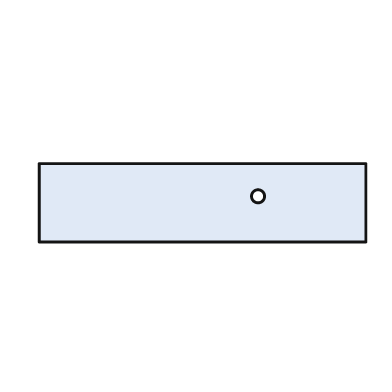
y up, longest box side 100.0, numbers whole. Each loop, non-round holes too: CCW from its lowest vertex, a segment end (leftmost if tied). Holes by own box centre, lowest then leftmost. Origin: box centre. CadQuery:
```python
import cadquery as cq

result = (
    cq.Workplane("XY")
    .moveTo(-50.0, -12.0)
    .lineTo(50.0, -12.0)
    .lineTo(50.0, 12.0)
    .lineTo(-50.0, 12.0)
    .close()
    .moveTo(17.0, 2.0)
    .circle(2.0)
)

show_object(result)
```